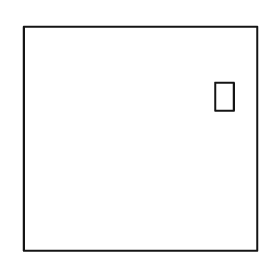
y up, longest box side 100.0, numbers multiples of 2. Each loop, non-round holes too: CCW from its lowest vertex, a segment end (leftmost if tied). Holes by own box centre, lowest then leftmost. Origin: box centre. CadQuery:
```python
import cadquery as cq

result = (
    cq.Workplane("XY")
    .moveTo(-50.0, -48.0)
    .lineTo(50.0, -48.0)
    .lineTo(50.0, 48.0)
    .lineTo(-50.0, 48.0)
    .close()
    .moveTo(32.0, 12.0)
    .lineTo(40.0, 12.0)
    .lineTo(40.0, 24.0)
    .lineTo(32.0, 24.0)
    .close()
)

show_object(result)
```